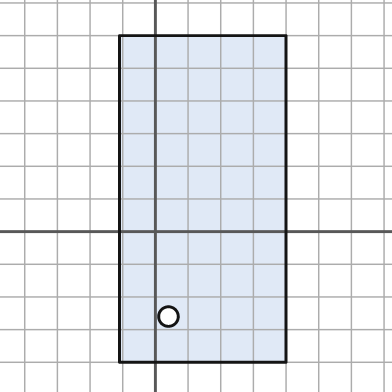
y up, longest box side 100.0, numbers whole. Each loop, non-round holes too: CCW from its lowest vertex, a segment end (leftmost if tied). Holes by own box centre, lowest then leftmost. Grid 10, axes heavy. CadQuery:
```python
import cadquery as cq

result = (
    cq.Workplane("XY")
    .moveTo(-11.0, -40.0)
    .lineTo(40.0, -40.0)
    .lineTo(40.0, 60.0)
    .lineTo(-11.0, 60.0)
    .close()
    .moveTo(4.0, -26.0)
    .circle(3.0)
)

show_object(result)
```